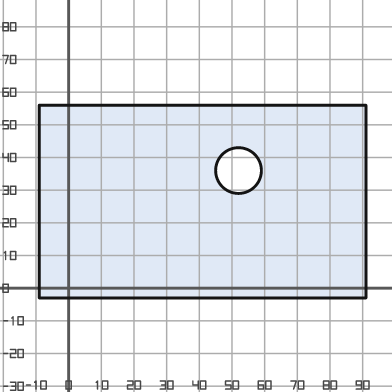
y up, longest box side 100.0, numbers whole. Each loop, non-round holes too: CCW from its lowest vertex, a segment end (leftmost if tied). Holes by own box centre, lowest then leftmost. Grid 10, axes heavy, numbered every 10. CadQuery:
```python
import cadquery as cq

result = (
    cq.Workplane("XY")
    .moveTo(-9.0, -3.0)
    .lineTo(91.0, -3.0)
    .lineTo(91.0, 56.0)
    .lineTo(-9.0, 56.0)
    .close()
    .moveTo(52.0, 36.0)
    .circle(7.0)
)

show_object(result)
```